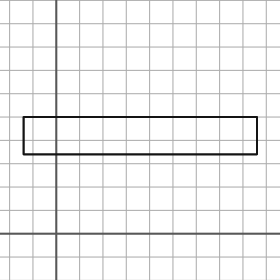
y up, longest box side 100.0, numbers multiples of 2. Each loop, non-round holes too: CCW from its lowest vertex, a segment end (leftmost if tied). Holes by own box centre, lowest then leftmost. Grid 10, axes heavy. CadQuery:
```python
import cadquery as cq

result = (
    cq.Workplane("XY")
    .moveTo(-14.0, 34.0)
    .lineTo(86.0, 34.0)
    .lineTo(86.0, 50.0)
    .lineTo(-14.0, 50.0)
    .close()
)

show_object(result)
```